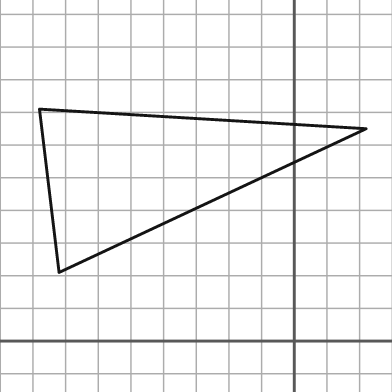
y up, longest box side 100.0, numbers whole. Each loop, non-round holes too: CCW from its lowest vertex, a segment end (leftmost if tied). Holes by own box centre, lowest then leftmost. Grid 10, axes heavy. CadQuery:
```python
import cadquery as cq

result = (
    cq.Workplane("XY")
    .moveTo(-72.0, 21.0)
    .lineTo(22.0, 65.0)
    .lineTo(-78.0, 71.0)
    .close()
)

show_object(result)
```